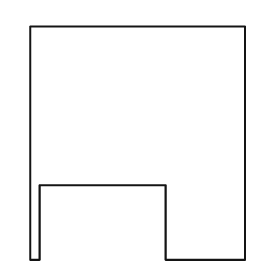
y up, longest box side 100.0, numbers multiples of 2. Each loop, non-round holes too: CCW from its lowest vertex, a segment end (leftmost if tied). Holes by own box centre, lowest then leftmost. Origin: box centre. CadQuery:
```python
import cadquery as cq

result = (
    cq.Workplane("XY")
    .moveTo(-46.0, -50.0)
    .lineTo(-42.0, -50.0)
    .lineTo(-42.0, -18.0)
    .lineTo(12.0, -18.0)
    .lineTo(12.0, -50.0)
    .lineTo(46.0, -50.0)
    .lineTo(46.0, 50.0)
    .lineTo(-46.0, 50.0)
    .close()
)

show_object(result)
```